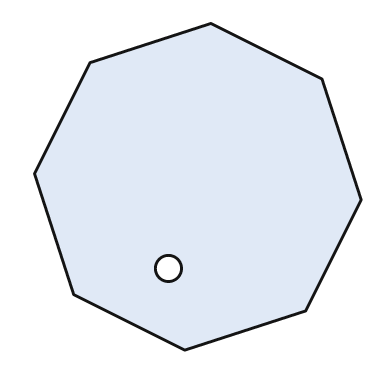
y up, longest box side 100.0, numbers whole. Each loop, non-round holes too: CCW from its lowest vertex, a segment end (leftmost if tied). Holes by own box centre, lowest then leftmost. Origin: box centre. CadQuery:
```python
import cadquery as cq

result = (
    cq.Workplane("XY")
    .moveTo(-4.0, -50.0)
    .lineTo(33.0, -38.0)
    .lineTo(50.0, -4.0)
    .lineTo(38.0, 33.0)
    .lineTo(4.0, 50.0)
    .lineTo(-33.0, 38.0)
    .lineTo(-50.0, 4.0)
    .lineTo(-38.0, -33.0)
    .close()
    .moveTo(-9.0, -25.0)
    .circle(4.0)
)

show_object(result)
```